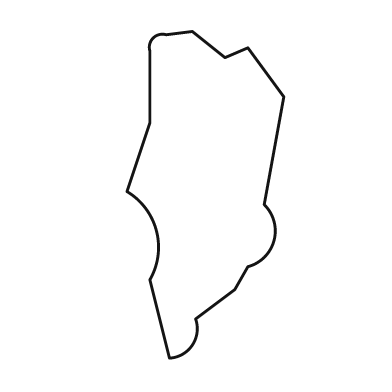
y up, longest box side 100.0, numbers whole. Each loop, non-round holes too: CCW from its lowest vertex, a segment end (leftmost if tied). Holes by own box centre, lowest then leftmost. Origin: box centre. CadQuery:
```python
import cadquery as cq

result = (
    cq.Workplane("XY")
    .moveTo(-11.0, -50.0)
    .threePointArc((-4.0, -46.0), (-3.0, -38.0))
    .lineTo(9.0, -29.0)
    .lineTo(13.0, -22.0)
    .threePointArc((21.0, -14.0), (18.0, -3.0))
    .lineTo(24.0, 30.0)
    .lineTo(13.0, 45.0)
    .lineTo(6.0, 42.0)
    .lineTo(-4.0, 50.0)
    .lineTo(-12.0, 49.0)
    .threePointArc((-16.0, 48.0), (-17.0, 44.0))
    .lineTo(-17.0, 22.0)
    .lineTo(-24.0, 1.0)
    .threePointArc((-15.0, -11.0), (-17.0, -26.0))
    .close()
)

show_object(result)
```